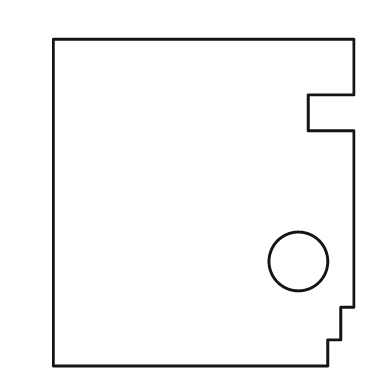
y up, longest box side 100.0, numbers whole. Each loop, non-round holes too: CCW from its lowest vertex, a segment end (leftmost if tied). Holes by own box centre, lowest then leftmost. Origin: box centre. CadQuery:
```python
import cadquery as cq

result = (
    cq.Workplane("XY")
    .moveTo(-46.0, -50.0)
    .lineTo(38.0, -50.0)
    .lineTo(38.0, -42.0)
    .lineTo(42.0, -42.0)
    .lineTo(42.0, -32.0)
    .lineTo(46.0, -32.0)
    .lineTo(46.0, 22.0)
    .lineTo(32.0, 22.0)
    .lineTo(32.0, 33.0)
    .lineTo(46.0, 33.0)
    .lineTo(46.0, 50.0)
    .lineTo(-46.0, 50.0)
    .close()
    .moveTo(29.0, -18.0)
    .circle(9.0)
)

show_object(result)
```